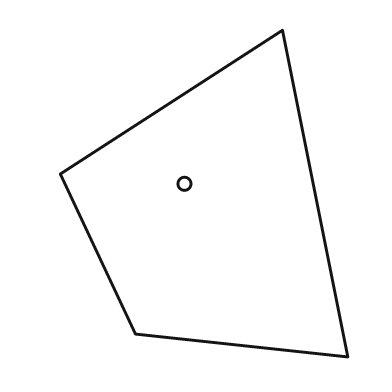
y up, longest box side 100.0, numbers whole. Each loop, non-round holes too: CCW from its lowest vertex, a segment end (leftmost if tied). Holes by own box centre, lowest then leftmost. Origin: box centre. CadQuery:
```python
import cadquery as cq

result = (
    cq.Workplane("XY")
    .moveTo(44.0, -50.0)
    .lineTo(24.0, 50.0)
    .lineTo(-44.0, 6.0)
    .lineTo(-21.0, -43.0)
    .close()
    .moveTo(-6.0, 3.0)
    .circle(2.0)
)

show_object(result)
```